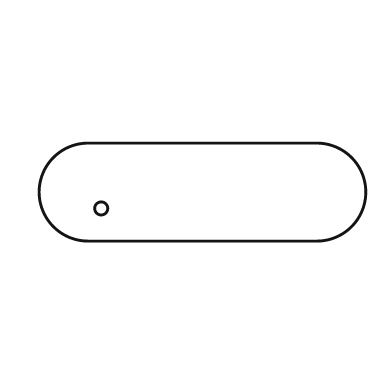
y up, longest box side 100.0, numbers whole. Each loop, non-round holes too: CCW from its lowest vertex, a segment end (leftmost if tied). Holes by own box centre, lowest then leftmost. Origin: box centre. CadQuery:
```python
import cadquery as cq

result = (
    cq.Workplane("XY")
    .moveTo(-35.0, -15.0)
    .lineTo(35.0, -15.0)
    .threePointArc((50.0, 0.0), (35.0, 15.0))
    .lineTo(-35.0, 15.0)
    .threePointArc((-50.0, 0.0), (-35.0, -15.0))
    .close()
    .moveTo(-31.0, -5.0)
    .circle(2.0)
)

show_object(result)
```